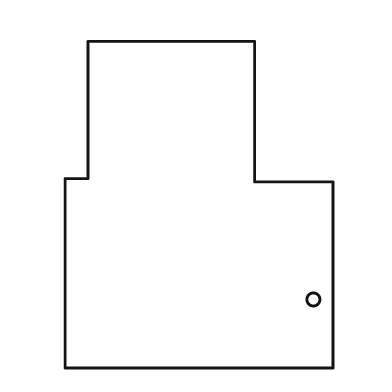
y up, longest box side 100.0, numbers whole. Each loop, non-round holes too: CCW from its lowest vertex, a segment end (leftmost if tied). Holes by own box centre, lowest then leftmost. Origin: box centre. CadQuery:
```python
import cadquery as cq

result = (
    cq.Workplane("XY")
    .moveTo(-41.0, -50.0)
    .lineTo(41.0, -50.0)
    .lineTo(41.0, 7.0)
    .lineTo(17.0, 7.0)
    .lineTo(17.0, 50.0)
    .lineTo(-34.0, 50.0)
    .lineTo(-34.0, 8.0)
    .lineTo(-41.0, 8.0)
    .close()
    .moveTo(35.0, -29.0)
    .circle(2.0)
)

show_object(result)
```